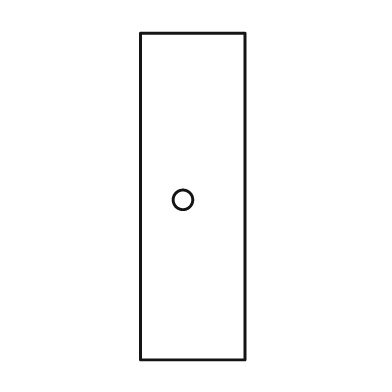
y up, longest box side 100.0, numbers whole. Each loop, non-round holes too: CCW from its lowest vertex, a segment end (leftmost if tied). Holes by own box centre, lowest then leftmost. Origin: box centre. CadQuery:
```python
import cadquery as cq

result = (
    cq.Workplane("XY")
    .moveTo(-16.0, -50.0)
    .lineTo(16.0, -50.0)
    .lineTo(16.0, 50.0)
    .lineTo(-16.0, 50.0)
    .close()
    .moveTo(-3.0, -1.0)
    .circle(3.0)
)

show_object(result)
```